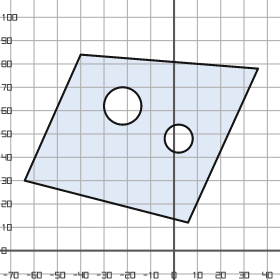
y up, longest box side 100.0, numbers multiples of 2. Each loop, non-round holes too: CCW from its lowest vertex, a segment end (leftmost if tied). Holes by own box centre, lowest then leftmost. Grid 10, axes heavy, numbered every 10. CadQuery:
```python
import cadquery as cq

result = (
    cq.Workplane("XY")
    .moveTo(6.0, 12.0)
    .lineTo(36.0, 78.0)
    .lineTo(-40.0, 84.0)
    .lineTo(-64.0, 30.0)
    .close()
    .moveTo(2.0, 48.0)
    .circle(6.0)
    .moveTo(-22.0, 62.0)
    .circle(8.0)
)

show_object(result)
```